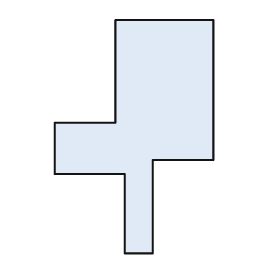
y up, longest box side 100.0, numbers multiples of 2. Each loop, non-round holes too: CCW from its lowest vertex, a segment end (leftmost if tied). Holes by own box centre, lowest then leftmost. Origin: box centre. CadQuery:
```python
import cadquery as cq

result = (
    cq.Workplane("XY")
    .moveTo(-4.0, -50.0)
    .lineTo(8.0, -50.0)
    .lineTo(8.0, -10.0)
    .lineTo(34.0, -10.0)
    .lineTo(34.0, 50.0)
    .lineTo(-8.0, 50.0)
    .lineTo(-8.0, 6.0)
    .lineTo(-34.0, 6.0)
    .lineTo(-34.0, -16.0)
    .lineTo(-4.0, -16.0)
    .close()
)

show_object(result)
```